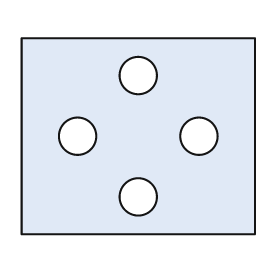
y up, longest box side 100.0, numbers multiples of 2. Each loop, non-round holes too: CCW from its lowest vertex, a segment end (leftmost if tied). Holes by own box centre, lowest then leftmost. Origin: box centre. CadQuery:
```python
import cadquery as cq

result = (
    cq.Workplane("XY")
    .moveTo(-50.0, -42.0)
    .lineTo(50.0, -42.0)
    .lineTo(50.0, 42.0)
    .lineTo(-50.0, 42.0)
    .close()
    .moveTo(0.0, -26.0)
    .circle(8.0)
    .moveTo(-26.0, 0.0)
    .circle(8.0)
    .moveTo(26.0, 0.0)
    .circle(8.0)
    .moveTo(0.0, 26.0)
    .circle(8.0)
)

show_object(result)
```